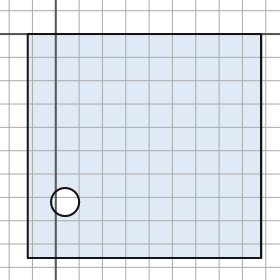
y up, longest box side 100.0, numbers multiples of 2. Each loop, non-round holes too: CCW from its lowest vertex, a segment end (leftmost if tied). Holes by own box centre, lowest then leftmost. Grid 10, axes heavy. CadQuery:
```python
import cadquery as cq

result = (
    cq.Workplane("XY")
    .moveTo(-12.0, -96.0)
    .lineTo(88.0, -96.0)
    .lineTo(88.0, 0.0)
    .lineTo(-12.0, 0.0)
    .close()
    .moveTo(4.0, -72.0)
    .circle(6.0)
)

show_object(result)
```